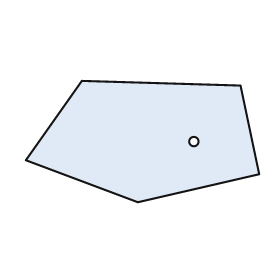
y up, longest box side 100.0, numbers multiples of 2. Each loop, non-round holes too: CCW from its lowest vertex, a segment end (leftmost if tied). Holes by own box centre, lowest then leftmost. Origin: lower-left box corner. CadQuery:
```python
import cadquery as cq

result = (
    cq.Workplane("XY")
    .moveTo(48.0, 0.0)
    .lineTo(100.0, 12.0)
    .lineTo(92.0, 50.0)
    .lineTo(24.0, 52.0)
    .lineTo(0.0, 18.0)
    .close()
    .moveTo(72.0, 26.0)
    .circle(2.0)
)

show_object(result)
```